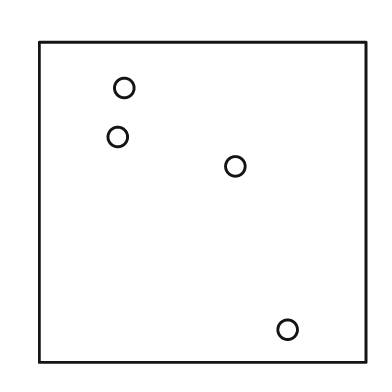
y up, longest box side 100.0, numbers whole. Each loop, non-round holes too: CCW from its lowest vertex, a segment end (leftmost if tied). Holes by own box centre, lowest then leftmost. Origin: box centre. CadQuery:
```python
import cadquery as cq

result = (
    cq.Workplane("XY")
    .moveTo(-50.0, -49.0)
    .lineTo(50.0, -49.0)
    .lineTo(50.0, 49.0)
    .lineTo(-50.0, 49.0)
    .close()
    .moveTo(26.0, -39.0)
    .circle(3.0)
    .moveTo(10.0, 11.0)
    .circle(3.0)
    .moveTo(-26.0, 20.0)
    .circle(3.0)
    .moveTo(-24.0, 35.0)
    .circle(3.0)
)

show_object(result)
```